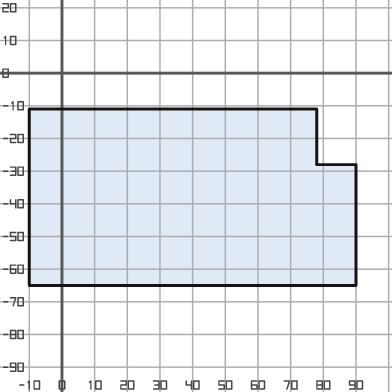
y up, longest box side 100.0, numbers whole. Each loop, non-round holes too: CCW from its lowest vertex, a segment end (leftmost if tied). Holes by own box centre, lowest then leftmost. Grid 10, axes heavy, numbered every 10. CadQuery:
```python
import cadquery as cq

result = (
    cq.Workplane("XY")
    .moveTo(-10.0, -65.0)
    .lineTo(90.0, -65.0)
    .lineTo(90.0, -28.0)
    .lineTo(78.0, -28.0)
    .lineTo(78.0, -11.0)
    .lineTo(-10.0, -11.0)
    .close()
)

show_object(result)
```